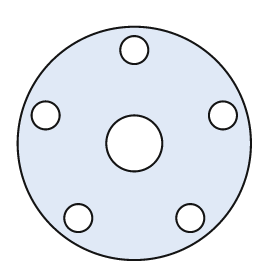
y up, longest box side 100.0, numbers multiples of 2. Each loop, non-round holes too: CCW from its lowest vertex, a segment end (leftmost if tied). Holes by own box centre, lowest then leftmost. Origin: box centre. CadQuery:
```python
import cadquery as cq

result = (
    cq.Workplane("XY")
    .moveTo(0.0, 0.0)
    .circle(50.0)
    .moveTo(-24.0, -32.0)
    .circle(6.0)
    .moveTo(24.0, -32.0)
    .circle(6.0)
    .moveTo(0.0, 0.0)
    .circle(12.0)
    .moveTo(-38.0, 12.0)
    .circle(6.0)
    .moveTo(38.0, 12.0)
    .circle(6.0)
    .moveTo(0.0, 40.0)
    .circle(6.0)
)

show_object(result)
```